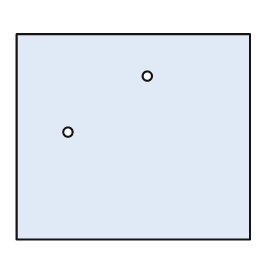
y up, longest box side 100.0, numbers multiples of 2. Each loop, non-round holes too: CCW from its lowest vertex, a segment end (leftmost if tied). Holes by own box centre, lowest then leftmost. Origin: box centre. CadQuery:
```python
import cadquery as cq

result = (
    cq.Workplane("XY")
    .moveTo(-50.0, -44.0)
    .lineTo(50.0, -44.0)
    .lineTo(50.0, 44.0)
    .lineTo(-50.0, 44.0)
    .close()
    .moveTo(-28.0, 2.0)
    .circle(2.0)
    .moveTo(6.0, 26.0)
    .circle(2.0)
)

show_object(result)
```